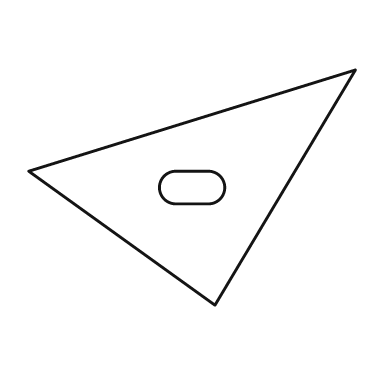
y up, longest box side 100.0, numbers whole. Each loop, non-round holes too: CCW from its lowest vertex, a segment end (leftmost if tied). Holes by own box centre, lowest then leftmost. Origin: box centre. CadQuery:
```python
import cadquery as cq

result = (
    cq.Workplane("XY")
    .moveTo(7.0, -36.0)
    .lineTo(50.0, 36.0)
    .lineTo(-50.0, 5.0)
    .close()
    .moveTo(-5.0, -5.0)
    .lineTo(5.0, -5.0)
    .threePointArc((10.0, 0.0), (5.0, 5.0))
    .lineTo(-5.0, 5.0)
    .threePointArc((-10.0, 0.0), (-5.0, -5.0))
    .close()
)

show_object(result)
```